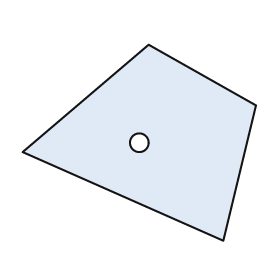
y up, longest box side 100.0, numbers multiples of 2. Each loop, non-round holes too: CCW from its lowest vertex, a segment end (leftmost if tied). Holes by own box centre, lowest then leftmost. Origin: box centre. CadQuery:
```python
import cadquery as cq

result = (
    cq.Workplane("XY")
    .moveTo(36.0, -42.0)
    .lineTo(50.0, 16.0)
    .lineTo(4.0, 42.0)
    .lineTo(-50.0, -4.0)
    .close()
    .moveTo(0.0, 0.0)
    .circle(4.0)
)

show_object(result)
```